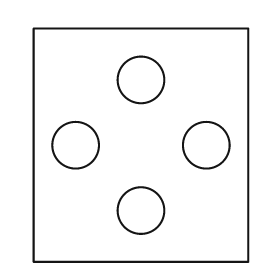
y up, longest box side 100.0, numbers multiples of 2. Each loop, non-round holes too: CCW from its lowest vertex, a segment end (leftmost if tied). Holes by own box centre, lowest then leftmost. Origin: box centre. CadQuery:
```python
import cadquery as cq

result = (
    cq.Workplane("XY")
    .moveTo(-46.0, -50.0)
    .lineTo(46.0, -50.0)
    .lineTo(46.0, 50.0)
    .lineTo(-46.0, 50.0)
    .close()
    .moveTo(0.0, -28.0)
    .circle(10.0)
    .moveTo(-28.0, 0.0)
    .circle(10.0)
    .moveTo(28.0, 0.0)
    .circle(10.0)
    .moveTo(0.0, 28.0)
    .circle(10.0)
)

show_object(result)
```